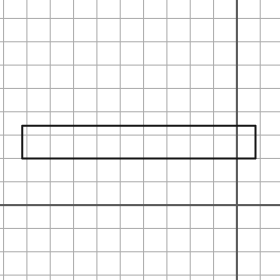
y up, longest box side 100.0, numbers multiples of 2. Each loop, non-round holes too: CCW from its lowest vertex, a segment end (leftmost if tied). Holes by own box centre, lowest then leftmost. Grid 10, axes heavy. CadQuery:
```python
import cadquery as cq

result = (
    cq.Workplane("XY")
    .moveTo(-92.0, 20.0)
    .lineTo(8.0, 20.0)
    .lineTo(8.0, 34.0)
    .lineTo(-92.0, 34.0)
    .close()
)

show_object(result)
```